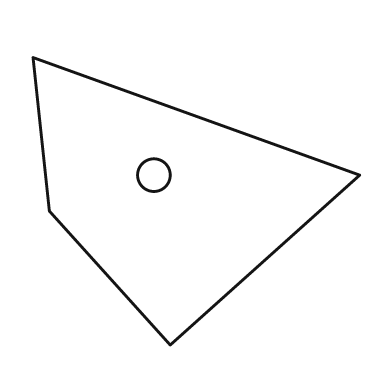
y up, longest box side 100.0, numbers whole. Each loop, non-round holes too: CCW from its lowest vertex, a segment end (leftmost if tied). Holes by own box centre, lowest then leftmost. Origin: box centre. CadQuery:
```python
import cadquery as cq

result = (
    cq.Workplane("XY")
    .moveTo(-8.0, -44.0)
    .lineTo(50.0, 8.0)
    .lineTo(-50.0, 44.0)
    .lineTo(-45.0, -3.0)
    .close()
    .moveTo(-13.0, 8.0)
    .circle(5.0)
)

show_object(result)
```